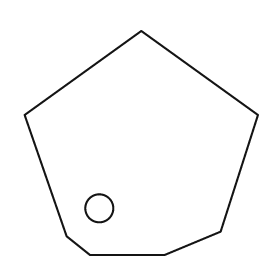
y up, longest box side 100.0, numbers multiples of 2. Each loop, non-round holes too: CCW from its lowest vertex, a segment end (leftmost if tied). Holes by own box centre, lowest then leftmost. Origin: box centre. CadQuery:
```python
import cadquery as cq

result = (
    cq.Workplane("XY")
    .moveTo(-22.0, -48.0)
    .lineTo(10.0, -48.0)
    .lineTo(34.0, -38.0)
    .lineTo(50.0, 12.0)
    .lineTo(0.0, 48.0)
    .lineTo(-50.0, 12.0)
    .lineTo(-32.0, -40.0)
    .close()
    .moveTo(-18.0, -28.0)
    .circle(6.0)
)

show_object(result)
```